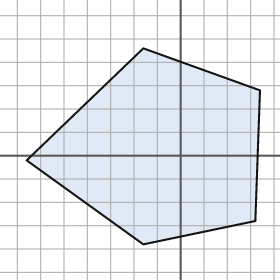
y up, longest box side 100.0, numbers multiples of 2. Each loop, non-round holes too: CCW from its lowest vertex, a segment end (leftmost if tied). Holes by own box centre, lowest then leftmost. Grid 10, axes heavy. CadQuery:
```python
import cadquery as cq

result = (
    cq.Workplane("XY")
    .moveTo(-16.0, -38.0)
    .lineTo(32.0, -28.0)
    .lineTo(34.0, 28.0)
    .lineTo(-16.0, 46.0)
    .lineTo(-66.0, -2.0)
    .close()
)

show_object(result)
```